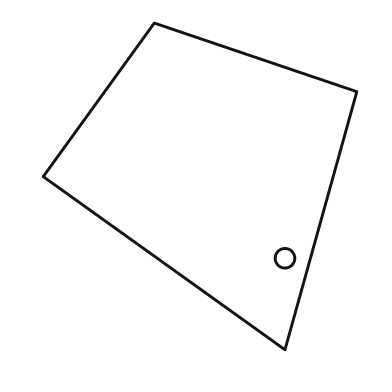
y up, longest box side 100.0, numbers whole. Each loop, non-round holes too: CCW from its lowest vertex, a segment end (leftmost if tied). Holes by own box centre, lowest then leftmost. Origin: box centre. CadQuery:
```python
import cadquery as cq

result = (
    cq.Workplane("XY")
    .moveTo(26.0, -50.0)
    .lineTo(48.0, 29.0)
    .lineTo(-14.0, 50.0)
    .lineTo(-48.0, 3.0)
    .close()
    .moveTo(26.0, -22.0)
    .circle(3.0)
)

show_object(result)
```